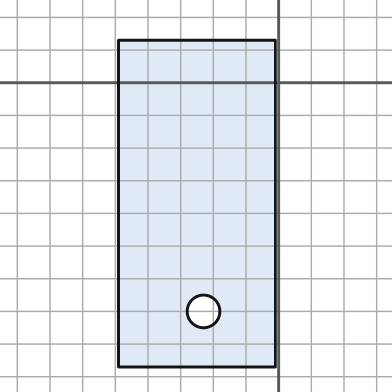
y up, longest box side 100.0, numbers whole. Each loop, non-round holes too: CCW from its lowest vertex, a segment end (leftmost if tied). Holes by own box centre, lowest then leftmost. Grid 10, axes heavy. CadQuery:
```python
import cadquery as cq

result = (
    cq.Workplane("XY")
    .moveTo(-49.0, -87.0)
    .lineTo(-1.0, -87.0)
    .lineTo(-1.0, 13.0)
    .lineTo(-49.0, 13.0)
    .close()
    .moveTo(-23.0, -70.0)
    .circle(5.0)
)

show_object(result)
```